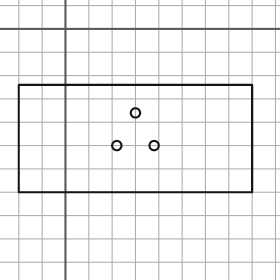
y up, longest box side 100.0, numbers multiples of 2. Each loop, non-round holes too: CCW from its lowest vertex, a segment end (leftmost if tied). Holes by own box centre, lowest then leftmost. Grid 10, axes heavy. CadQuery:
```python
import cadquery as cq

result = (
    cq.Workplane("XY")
    .moveTo(-20.0, -70.0)
    .lineTo(80.0, -70.0)
    .lineTo(80.0, -24.0)
    .lineTo(-20.0, -24.0)
    .close()
    .moveTo(22.0, -50.0)
    .circle(2.0)
    .moveTo(38.0, -50.0)
    .circle(2.0)
    .moveTo(30.0, -36.0)
    .circle(2.0)
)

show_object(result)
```